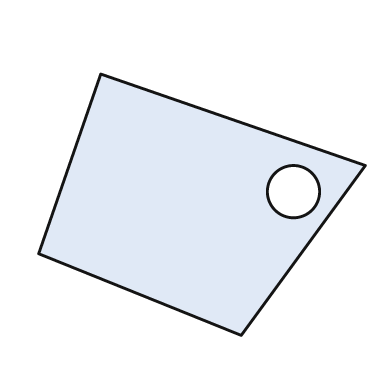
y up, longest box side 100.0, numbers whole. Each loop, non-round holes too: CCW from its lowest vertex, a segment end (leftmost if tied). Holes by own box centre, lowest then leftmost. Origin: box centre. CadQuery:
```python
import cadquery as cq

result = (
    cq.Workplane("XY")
    .moveTo(12.0, -40.0)
    .lineTo(50.0, 12.0)
    .lineTo(-31.0, 40.0)
    .lineTo(-50.0, -15.0)
    .close()
    .moveTo(28.0, 4.0)
    .circle(8.0)
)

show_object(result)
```